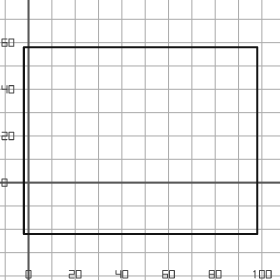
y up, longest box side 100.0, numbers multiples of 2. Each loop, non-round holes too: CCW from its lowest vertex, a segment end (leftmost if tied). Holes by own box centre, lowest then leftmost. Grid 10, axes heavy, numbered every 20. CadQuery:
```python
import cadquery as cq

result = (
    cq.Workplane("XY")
    .moveTo(-2.0, -22.0)
    .lineTo(98.0, -22.0)
    .lineTo(98.0, 58.0)
    .lineTo(-2.0, 58.0)
    .close()
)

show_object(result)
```